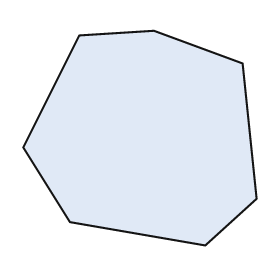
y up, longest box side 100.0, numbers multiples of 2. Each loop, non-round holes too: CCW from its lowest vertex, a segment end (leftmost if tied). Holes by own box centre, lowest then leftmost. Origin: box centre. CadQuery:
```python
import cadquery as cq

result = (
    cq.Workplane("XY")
    .moveTo(28.0, -46.0)
    .lineTo(50.0, -26.0)
    .lineTo(44.0, 32.0)
    .lineTo(6.0, 46.0)
    .lineTo(-26.0, 44.0)
    .lineTo(-50.0, -4.0)
    .lineTo(-30.0, -36.0)
    .close()
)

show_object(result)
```